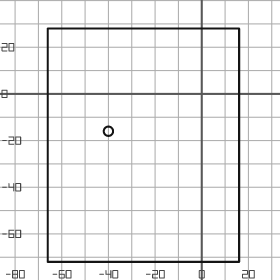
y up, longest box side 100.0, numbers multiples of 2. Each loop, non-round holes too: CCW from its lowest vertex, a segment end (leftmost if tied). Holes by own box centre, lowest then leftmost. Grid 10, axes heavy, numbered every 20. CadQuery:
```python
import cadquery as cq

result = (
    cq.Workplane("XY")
    .moveTo(-66.0, -72.0)
    .lineTo(16.0, -72.0)
    .lineTo(16.0, 28.0)
    .lineTo(-66.0, 28.0)
    .close()
    .moveTo(-40.0, -16.0)
    .circle(2.0)
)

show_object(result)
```